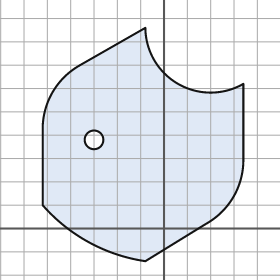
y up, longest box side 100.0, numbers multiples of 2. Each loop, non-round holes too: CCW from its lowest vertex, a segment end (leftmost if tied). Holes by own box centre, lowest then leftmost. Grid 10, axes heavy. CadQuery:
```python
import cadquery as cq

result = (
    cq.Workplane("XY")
    .moveTo(-8.0, -14.0)
    .lineTo(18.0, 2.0)
    .threePointArc((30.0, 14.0), (34.0, 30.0))
    .lineTo(34.0, 62.0)
    .threePointArc((6.0, 62.0), (-8.0, 86.0))
    .lineTo(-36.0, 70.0)
    .threePointArc((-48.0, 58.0), (-52.0, 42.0))
    .lineTo(-52.0, 10.0)
    .threePointArc((-32.0, -6.0), (-8.0, -14.0))
    .close()
    .moveTo(-30.0, 38.0)
    .circle(4.0)
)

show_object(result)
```